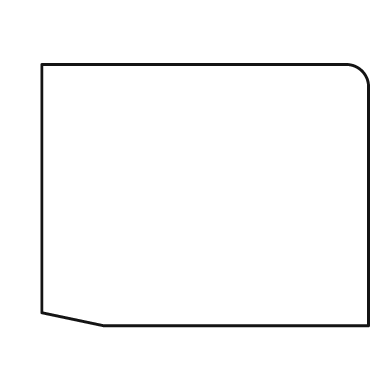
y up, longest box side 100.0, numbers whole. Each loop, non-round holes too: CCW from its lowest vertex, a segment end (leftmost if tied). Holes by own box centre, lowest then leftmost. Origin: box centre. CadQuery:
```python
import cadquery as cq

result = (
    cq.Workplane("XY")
    .moveTo(-31.0, -40.0)
    .lineTo(50.0, -40.0)
    .lineTo(50.0, 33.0)
    .threePointArc((48.0, 38.0), (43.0, 40.0))
    .lineTo(-50.0, 40.0)
    .lineTo(-50.0, -36.0)
    .close()
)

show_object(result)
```